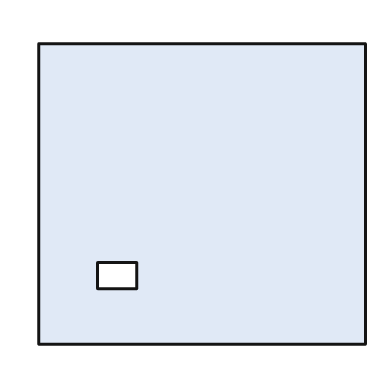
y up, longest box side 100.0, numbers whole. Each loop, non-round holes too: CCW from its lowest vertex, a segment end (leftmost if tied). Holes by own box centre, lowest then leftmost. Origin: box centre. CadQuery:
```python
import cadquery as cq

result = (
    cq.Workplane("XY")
    .moveTo(-50.0, -46.0)
    .lineTo(50.0, -46.0)
    .lineTo(50.0, 46.0)
    .lineTo(-50.0, 46.0)
    .close()
    .moveTo(-32.0, -29.0)
    .lineTo(-20.0, -29.0)
    .lineTo(-20.0, -21.0)
    .lineTo(-32.0, -21.0)
    .close()
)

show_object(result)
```